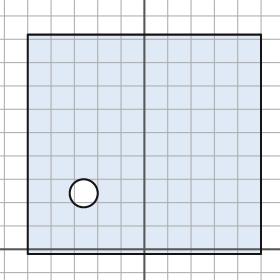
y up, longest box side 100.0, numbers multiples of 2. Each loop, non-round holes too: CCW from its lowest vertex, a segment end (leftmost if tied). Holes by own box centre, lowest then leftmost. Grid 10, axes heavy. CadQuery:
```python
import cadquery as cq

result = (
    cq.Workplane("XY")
    .moveTo(-50.0, -2.0)
    .lineTo(50.0, -2.0)
    .lineTo(50.0, 92.0)
    .lineTo(-50.0, 92.0)
    .close()
    .moveTo(-26.0, 24.0)
    .circle(6.0)
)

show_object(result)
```